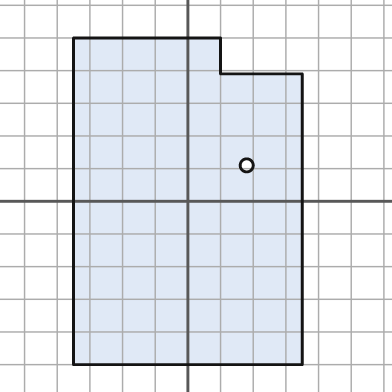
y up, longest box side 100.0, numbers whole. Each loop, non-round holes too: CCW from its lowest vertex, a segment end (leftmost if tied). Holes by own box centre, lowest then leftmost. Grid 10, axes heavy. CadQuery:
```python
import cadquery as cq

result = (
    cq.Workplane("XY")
    .moveTo(-35.0, -50.0)
    .lineTo(35.0, -50.0)
    .lineTo(35.0, 39.0)
    .lineTo(10.0, 39.0)
    .lineTo(10.0, 50.0)
    .lineTo(-35.0, 50.0)
    .close()
    .moveTo(18.0, 11.0)
    .circle(2.0)
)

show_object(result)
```